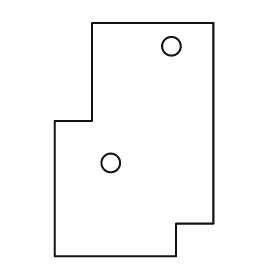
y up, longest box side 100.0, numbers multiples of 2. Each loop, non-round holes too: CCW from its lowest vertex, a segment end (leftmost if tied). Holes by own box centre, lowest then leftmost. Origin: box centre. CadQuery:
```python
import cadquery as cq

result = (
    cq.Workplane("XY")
    .moveTo(-34.0, -50.0)
    .lineTo(18.0, -50.0)
    .lineTo(18.0, -36.0)
    .lineTo(34.0, -36.0)
    .lineTo(34.0, 50.0)
    .lineTo(-18.0, 50.0)
    .lineTo(-18.0, 8.0)
    .lineTo(-34.0, 8.0)
    .close()
    .moveTo(-10.0, -10.0)
    .circle(4.0)
    .moveTo(16.0, 40.0)
    .circle(4.0)
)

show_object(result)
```